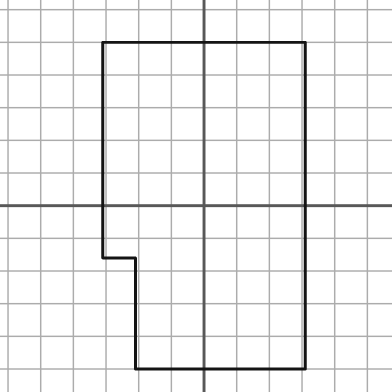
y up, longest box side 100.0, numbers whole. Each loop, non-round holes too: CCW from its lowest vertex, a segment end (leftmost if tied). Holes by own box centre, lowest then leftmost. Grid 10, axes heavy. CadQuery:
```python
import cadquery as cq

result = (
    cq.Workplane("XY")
    .moveTo(-21.0, -50.0)
    .lineTo(31.0, -50.0)
    .lineTo(31.0, 50.0)
    .lineTo(-31.0, 50.0)
    .lineTo(-31.0, -16.0)
    .lineTo(-21.0, -16.0)
    .close()
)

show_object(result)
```